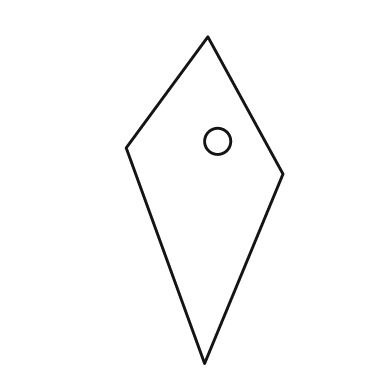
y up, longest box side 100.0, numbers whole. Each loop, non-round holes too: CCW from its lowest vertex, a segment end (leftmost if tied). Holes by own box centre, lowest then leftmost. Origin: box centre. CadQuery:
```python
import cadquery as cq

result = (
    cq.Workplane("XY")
    .moveTo(0.0, -50.0)
    .lineTo(24.0, 8.0)
    .lineTo(1.0, 50.0)
    .lineTo(-24.0, 16.0)
    .close()
    .moveTo(4.0, 18.0)
    .circle(4.0)
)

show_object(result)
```